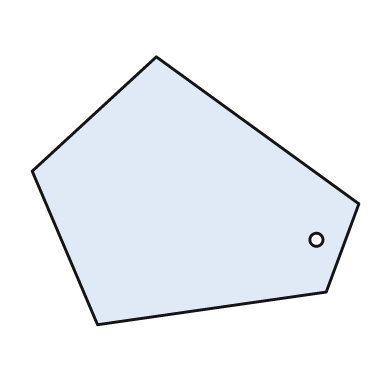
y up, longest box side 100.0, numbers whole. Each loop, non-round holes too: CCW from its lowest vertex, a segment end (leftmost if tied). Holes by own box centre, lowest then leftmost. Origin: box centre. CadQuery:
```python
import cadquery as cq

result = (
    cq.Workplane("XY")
    .moveTo(-30.0, -41.0)
    .lineTo(40.0, -31.0)
    .lineTo(50.0, -4.0)
    .lineTo(-12.0, 41.0)
    .lineTo(-50.0, 6.0)
    .close()
    .moveTo(37.0, -15.0)
    .circle(2.0)
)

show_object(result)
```